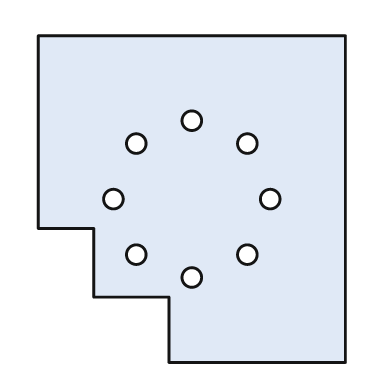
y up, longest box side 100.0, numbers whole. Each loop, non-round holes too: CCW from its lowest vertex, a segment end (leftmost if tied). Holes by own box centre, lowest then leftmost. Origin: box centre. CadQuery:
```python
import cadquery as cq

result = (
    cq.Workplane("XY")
    .moveTo(-7.0, -50.0)
    .lineTo(47.0, -50.0)
    .lineTo(47.0, 50.0)
    .lineTo(-47.0, 50.0)
    .lineTo(-47.0, -9.0)
    .lineTo(-30.0, -9.0)
    .lineTo(-30.0, -30.0)
    .lineTo(-7.0, -30.0)
    .close()
    .moveTo(0.0, -24.0)
    .circle(3.0)
    .moveTo(-17.0, -17.0)
    .circle(3.0)
    .moveTo(17.0, -17.0)
    .circle(3.0)
    .moveTo(-24.0, 0.0)
    .circle(3.0)
    .moveTo(24.0, 0.0)
    .circle(3.0)
    .moveTo(-17.0, 17.0)
    .circle(3.0)
    .moveTo(17.0, 17.0)
    .circle(3.0)
    .moveTo(0.0, 24.0)
    .circle(3.0)
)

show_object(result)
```